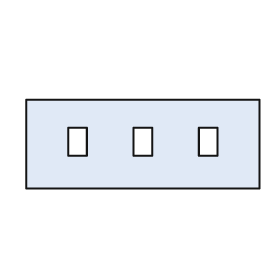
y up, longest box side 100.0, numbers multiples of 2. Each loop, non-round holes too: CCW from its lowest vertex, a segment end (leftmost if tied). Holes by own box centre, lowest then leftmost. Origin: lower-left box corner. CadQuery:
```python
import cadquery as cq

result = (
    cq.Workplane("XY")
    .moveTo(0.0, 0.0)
    .lineTo(100.0, 0.0)
    .lineTo(100.0, 38.0)
    .lineTo(0.0, 38.0)
    .close()
    .moveTo(18.0, 14.0)
    .lineTo(26.0, 14.0)
    .lineTo(26.0, 26.0)
    .lineTo(18.0, 26.0)
    .close()
    .moveTo(46.0, 14.0)
    .lineTo(54.0, 14.0)
    .lineTo(54.0, 26.0)
    .lineTo(46.0, 26.0)
    .close()
    .moveTo(74.0, 14.0)
    .lineTo(82.0, 14.0)
    .lineTo(82.0, 26.0)
    .lineTo(74.0, 26.0)
    .close()
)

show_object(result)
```